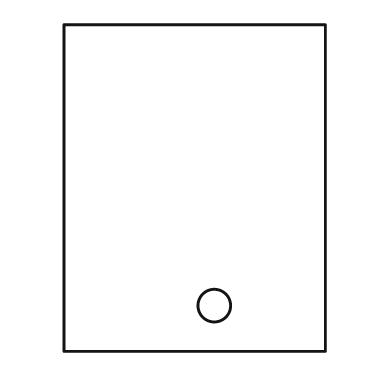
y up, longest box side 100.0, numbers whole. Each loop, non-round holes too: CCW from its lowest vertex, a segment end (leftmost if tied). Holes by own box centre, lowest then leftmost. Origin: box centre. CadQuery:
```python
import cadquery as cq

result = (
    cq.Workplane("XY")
    .moveTo(-40.0, -50.0)
    .lineTo(40.0, -50.0)
    .lineTo(40.0, 50.0)
    .lineTo(-40.0, 50.0)
    .close()
    .moveTo(6.0, -36.0)
    .circle(5.0)
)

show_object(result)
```